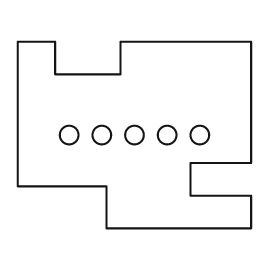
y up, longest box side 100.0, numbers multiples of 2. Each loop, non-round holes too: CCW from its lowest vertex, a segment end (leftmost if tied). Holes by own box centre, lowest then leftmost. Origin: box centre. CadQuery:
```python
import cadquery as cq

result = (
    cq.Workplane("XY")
    .moveTo(-12.0, -40.0)
    .lineTo(50.0, -40.0)
    .lineTo(50.0, -26.0)
    .lineTo(24.0, -26.0)
    .lineTo(24.0, -12.0)
    .lineTo(50.0, -12.0)
    .lineTo(50.0, 40.0)
    .lineTo(-6.0, 40.0)
    .lineTo(-6.0, 26.0)
    .lineTo(-34.0, 26.0)
    .lineTo(-34.0, 40.0)
    .lineTo(-50.0, 40.0)
    .lineTo(-50.0, -22.0)
    .lineTo(-12.0, -22.0)
    .close()
    .moveTo(-28.0, 0.0)
    .circle(4.0)
    .moveTo(-14.0, 0.0)
    .circle(4.0)
    .moveTo(0.0, 0.0)
    .circle(4.0)
    .moveTo(14.0, 0.0)
    .circle(4.0)
    .moveTo(28.0, 0.0)
    .circle(4.0)
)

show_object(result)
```